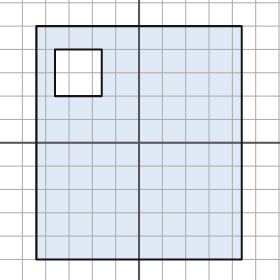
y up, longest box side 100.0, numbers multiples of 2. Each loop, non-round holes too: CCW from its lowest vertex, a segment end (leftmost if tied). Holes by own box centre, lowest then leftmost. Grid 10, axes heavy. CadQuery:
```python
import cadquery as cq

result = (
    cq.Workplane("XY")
    .moveTo(-44.0, -50.0)
    .lineTo(44.0, -50.0)
    .lineTo(44.0, 50.0)
    .lineTo(-44.0, 50.0)
    .close()
    .moveTo(-36.0, 20.0)
    .lineTo(-16.0, 20.0)
    .lineTo(-16.0, 40.0)
    .lineTo(-36.0, 40.0)
    .close()
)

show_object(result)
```